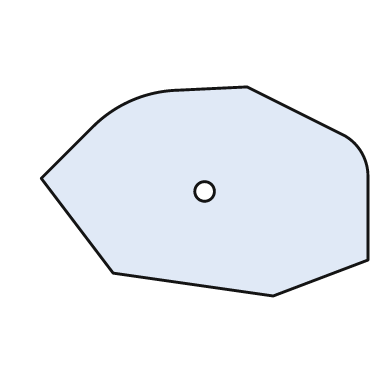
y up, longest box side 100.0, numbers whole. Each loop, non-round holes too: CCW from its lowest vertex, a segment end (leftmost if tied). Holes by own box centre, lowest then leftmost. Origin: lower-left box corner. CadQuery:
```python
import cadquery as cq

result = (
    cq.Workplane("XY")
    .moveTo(71.0, 0.0)
    .lineTo(100.0, 11.0)
    .lineTo(100.0, 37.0)
    .threePointArc((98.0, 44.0), (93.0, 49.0))
    .lineTo(63.0, 64.0)
    .lineTo(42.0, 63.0)
    .threePointArc((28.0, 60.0), (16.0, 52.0))
    .lineTo(0.0, 36.0)
    .lineTo(22.0, 7.0)
    .close()
    .moveTo(50.0, 32.0)
    .circle(3.0)
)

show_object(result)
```